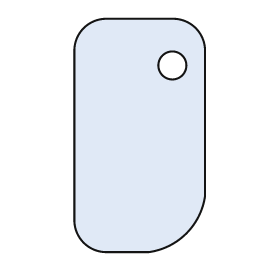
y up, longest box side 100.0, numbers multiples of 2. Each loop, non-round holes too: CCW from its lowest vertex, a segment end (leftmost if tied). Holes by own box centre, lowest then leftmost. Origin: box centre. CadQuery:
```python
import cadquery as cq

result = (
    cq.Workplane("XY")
    .moveTo(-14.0, -50.0)
    .lineTo(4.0, -50.0)
    .threePointArc((20.0, -42.0), (28.0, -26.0))
    .lineTo(28.0, 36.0)
    .threePointArc((24.0, 46.0), (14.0, 50.0))
    .lineTo(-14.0, 50.0)
    .threePointArc((-24.0, 46.0), (-28.0, 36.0))
    .lineTo(-28.0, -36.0)
    .threePointArc((-24.0, -46.0), (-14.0, -50.0))
    .close()
    .moveTo(14.0, 30.0)
    .circle(6.0)
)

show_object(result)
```